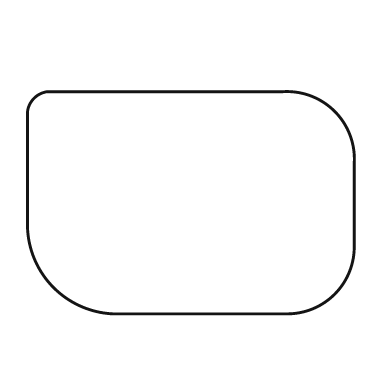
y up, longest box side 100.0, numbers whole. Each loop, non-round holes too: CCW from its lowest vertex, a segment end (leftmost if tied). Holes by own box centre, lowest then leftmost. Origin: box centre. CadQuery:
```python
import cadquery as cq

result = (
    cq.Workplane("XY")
    .moveTo(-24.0, -34.0)
    .lineTo(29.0, -34.0)
    .threePointArc((44.0, -28.0), (50.0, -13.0))
    .lineTo(50.0, 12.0)
    .threePointArc((44.0, 28.0), (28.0, 34.0))
    .lineTo(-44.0, 34.0)
    .threePointArc((-48.0, 32.0), (-50.0, 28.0))
    .lineTo(-50.0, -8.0)
    .threePointArc((-42.0, -26.0), (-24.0, -34.0))
    .close()
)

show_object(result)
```